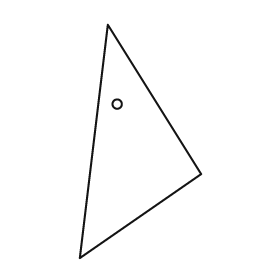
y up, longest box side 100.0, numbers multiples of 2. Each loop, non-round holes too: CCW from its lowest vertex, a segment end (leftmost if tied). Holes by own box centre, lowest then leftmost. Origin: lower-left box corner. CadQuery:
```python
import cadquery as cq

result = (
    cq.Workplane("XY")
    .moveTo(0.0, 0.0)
    .lineTo(52.0, 36.0)
    .lineTo(12.0, 100.0)
    .close()
    .moveTo(16.0, 66.0)
    .circle(2.0)
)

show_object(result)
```